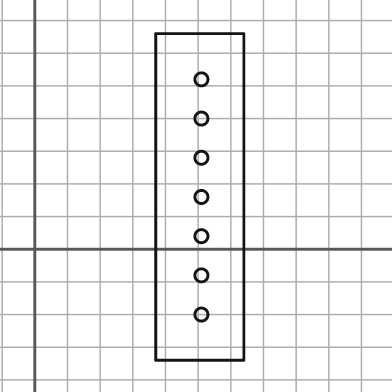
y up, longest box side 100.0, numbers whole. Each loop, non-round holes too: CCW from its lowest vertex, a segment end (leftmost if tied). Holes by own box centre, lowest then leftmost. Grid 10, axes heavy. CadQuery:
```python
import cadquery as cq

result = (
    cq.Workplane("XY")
    .moveTo(37.0, -34.0)
    .lineTo(64.0, -34.0)
    .lineTo(64.0, 66.0)
    .lineTo(37.0, 66.0)
    .close()
    .moveTo(51.0, -20.0)
    .circle(2.0)
    .moveTo(51.0, -8.0)
    .circle(2.0)
    .moveTo(51.0, 4.0)
    .circle(2.0)
    .moveTo(51.0, 16.0)
    .circle(2.0)
    .moveTo(51.0, 28.0)
    .circle(2.0)
    .moveTo(51.0, 40.0)
    .circle(2.0)
    .moveTo(51.0, 52.0)
    .circle(2.0)
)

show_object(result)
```